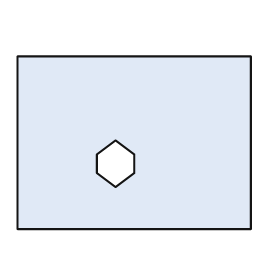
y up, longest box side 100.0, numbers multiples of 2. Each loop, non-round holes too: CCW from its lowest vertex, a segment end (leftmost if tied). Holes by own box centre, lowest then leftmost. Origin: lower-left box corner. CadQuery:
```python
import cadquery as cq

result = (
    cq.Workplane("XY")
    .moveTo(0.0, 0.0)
    .lineTo(100.0, 0.0)
    .lineTo(100.0, 74.0)
    .lineTo(0.0, 74.0)
    .close()
    .moveTo(42.0, 18.0)
    .lineTo(50.0, 24.0)
    .lineTo(50.0, 32.0)
    .lineTo(42.0, 38.0)
    .lineTo(34.0, 32.0)
    .lineTo(34.0, 24.0)
    .close()
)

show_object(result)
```